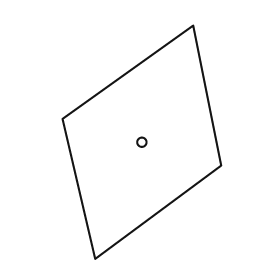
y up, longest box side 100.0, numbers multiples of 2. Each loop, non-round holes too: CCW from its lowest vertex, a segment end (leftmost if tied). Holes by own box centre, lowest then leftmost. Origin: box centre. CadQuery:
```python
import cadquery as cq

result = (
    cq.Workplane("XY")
    .moveTo(-20.0, -50.0)
    .lineTo(34.0, -10.0)
    .lineTo(22.0, 50.0)
    .lineTo(-34.0, 10.0)
    .close()
    .moveTo(0.0, 0.0)
    .circle(2.0)
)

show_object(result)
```